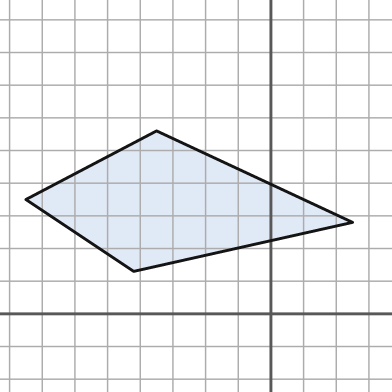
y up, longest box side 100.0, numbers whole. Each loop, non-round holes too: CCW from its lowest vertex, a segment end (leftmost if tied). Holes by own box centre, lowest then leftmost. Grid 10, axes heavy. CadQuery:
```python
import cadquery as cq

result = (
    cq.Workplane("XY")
    .moveTo(-42.0, 13.0)
    .lineTo(25.0, 28.0)
    .lineTo(-35.0, 56.0)
    .lineTo(-75.0, 35.0)
    .close()
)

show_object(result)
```